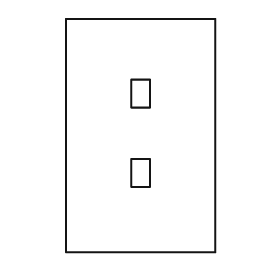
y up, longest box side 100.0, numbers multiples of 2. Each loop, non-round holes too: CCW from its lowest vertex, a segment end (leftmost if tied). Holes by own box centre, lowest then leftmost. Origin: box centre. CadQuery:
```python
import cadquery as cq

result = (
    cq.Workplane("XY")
    .moveTo(-32.0, -50.0)
    .lineTo(32.0, -50.0)
    .lineTo(32.0, 50.0)
    .lineTo(-32.0, 50.0)
    .close()
    .moveTo(-4.0, -22.0)
    .lineTo(4.0, -22.0)
    .lineTo(4.0, -10.0)
    .lineTo(-4.0, -10.0)
    .close()
    .moveTo(-4.0, 12.0)
    .lineTo(4.0, 12.0)
    .lineTo(4.0, 24.0)
    .lineTo(-4.0, 24.0)
    .close()
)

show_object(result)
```